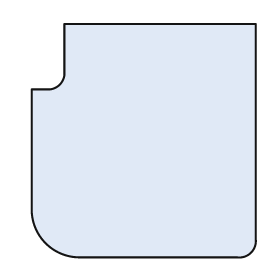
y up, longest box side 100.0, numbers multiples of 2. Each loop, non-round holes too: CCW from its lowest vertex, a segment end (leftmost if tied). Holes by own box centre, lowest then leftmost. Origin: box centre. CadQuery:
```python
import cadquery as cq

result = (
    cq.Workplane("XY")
    .moveTo(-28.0, -50.0)
    .lineTo(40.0, -50.0)
    .threePointArc((46.0, -48.0), (48.0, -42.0))
    .lineTo(48.0, 50.0)
    .lineTo(-34.0, 50.0)
    .lineTo(-34.0, 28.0)
    .threePointArc((-36.0, 24.0), (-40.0, 22.0))
    .lineTo(-48.0, 22.0)
    .lineTo(-48.0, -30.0)
    .threePointArc((-42.0, -44.0), (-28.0, -50.0))
    .close()
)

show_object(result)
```